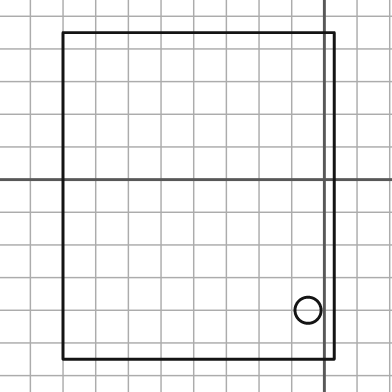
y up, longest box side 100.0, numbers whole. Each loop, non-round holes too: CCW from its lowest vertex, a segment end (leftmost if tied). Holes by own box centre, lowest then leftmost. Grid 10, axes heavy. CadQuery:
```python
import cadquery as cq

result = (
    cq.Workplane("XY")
    .moveTo(-80.0, -55.0)
    .lineTo(3.0, -55.0)
    .lineTo(3.0, 45.0)
    .lineTo(-80.0, 45.0)
    .close()
    .moveTo(-5.0, -40.0)
    .circle(4.0)
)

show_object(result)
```